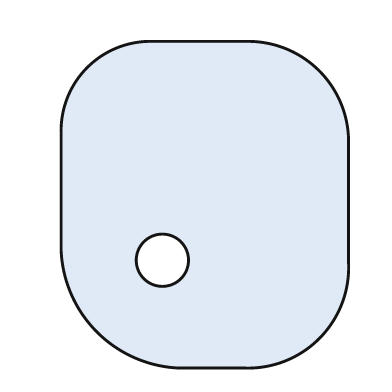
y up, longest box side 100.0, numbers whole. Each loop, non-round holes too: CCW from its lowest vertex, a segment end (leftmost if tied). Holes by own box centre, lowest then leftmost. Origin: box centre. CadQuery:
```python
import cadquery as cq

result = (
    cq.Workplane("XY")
    .moveTo(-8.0, -50.0)
    .lineTo(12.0, -50.0)
    .threePointArc((35.0, -41.0), (44.0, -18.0))
    .lineTo(44.0, 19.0)
    .threePointArc((35.0, 41.0), (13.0, 50.0))
    .lineTo(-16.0, 50.0)
    .threePointArc((-36.0, 42.0), (-44.0, 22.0))
    .lineTo(-44.0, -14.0)
    .threePointArc((-33.0, -39.0), (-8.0, -50.0))
    .close()
    .moveTo(-13.0, -17.0)
    .circle(8.0)
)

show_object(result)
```